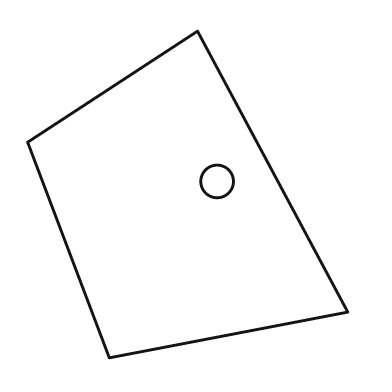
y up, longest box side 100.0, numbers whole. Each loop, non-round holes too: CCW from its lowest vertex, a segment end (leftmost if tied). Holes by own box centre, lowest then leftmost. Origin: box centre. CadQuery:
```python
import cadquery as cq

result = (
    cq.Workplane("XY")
    .moveTo(-24.0, -50.0)
    .lineTo(49.0, -36.0)
    .lineTo(3.0, 50.0)
    .lineTo(-49.0, 16.0)
    .close()
    .moveTo(9.0, 4.0)
    .circle(5.0)
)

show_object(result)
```